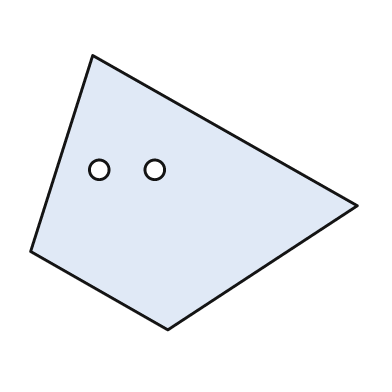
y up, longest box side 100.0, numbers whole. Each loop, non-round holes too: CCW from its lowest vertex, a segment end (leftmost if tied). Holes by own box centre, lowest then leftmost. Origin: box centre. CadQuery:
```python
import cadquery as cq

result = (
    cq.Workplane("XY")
    .moveTo(-8.0, -42.0)
    .lineTo(50.0, -4.0)
    .lineTo(-31.0, 42.0)
    .lineTo(-50.0, -18.0)
    .close()
    .moveTo(-29.0, 7.0)
    .circle(3.0)
    .moveTo(-12.0, 7.0)
    .circle(3.0)
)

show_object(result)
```